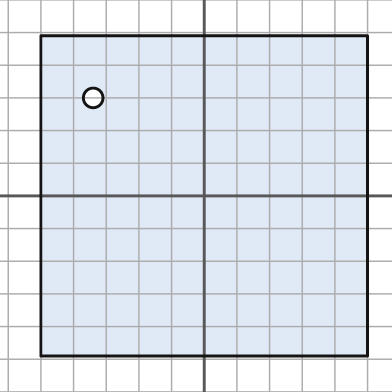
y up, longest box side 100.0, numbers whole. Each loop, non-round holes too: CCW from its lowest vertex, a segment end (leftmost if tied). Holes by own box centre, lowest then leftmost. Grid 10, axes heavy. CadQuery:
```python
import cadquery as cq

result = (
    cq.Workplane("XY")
    .moveTo(-50.0, -49.0)
    .lineTo(50.0, -49.0)
    .lineTo(50.0, 49.0)
    .lineTo(-50.0, 49.0)
    .close()
    .moveTo(-34.0, 30.0)
    .circle(3.0)
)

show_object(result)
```